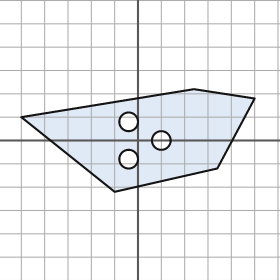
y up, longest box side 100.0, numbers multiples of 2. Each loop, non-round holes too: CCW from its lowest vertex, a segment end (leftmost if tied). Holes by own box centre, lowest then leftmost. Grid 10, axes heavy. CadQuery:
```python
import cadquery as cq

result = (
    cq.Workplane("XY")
    .moveTo(-10.0, -22.0)
    .lineTo(34.0, -12.0)
    .lineTo(50.0, 18.0)
    .lineTo(24.0, 22.0)
    .lineTo(-50.0, 10.0)
    .close()
    .moveTo(-4.0, -8.0)
    .circle(4.0)
    .moveTo(10.0, 0.0)
    .circle(4.0)
    .moveTo(-4.0, 8.0)
    .circle(4.0)
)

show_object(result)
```